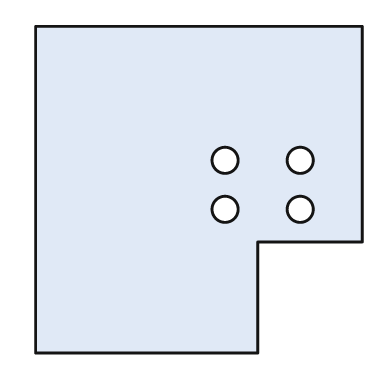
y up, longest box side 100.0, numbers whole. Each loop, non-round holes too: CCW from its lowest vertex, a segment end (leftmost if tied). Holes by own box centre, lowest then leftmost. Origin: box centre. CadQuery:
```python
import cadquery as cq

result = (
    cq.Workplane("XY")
    .moveTo(-50.0, -50.0)
    .lineTo(18.0, -50.0)
    .lineTo(18.0, -16.0)
    .lineTo(50.0, -16.0)
    .lineTo(50.0, 50.0)
    .lineTo(-50.0, 50.0)
    .close()
    .moveTo(8.0, -6.0)
    .circle(4.0)
    .moveTo(31.0, -6.0)
    .circle(4.0)
    .moveTo(8.0, 9.0)
    .circle(4.0)
    .moveTo(31.0, 9.0)
    .circle(4.0)
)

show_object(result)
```